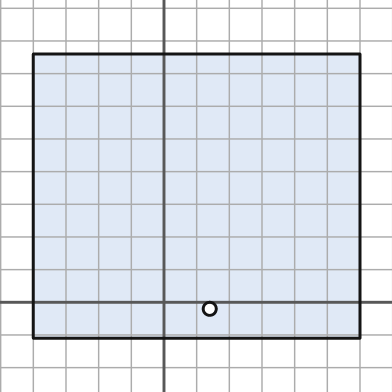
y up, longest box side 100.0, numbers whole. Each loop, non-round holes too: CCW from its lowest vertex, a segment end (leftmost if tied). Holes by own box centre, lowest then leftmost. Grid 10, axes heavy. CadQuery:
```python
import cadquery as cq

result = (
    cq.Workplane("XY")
    .moveTo(-40.0, -11.0)
    .lineTo(60.0, -11.0)
    .lineTo(60.0, 76.0)
    .lineTo(-40.0, 76.0)
    .close()
    .moveTo(14.0, -2.0)
    .circle(2.0)
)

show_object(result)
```